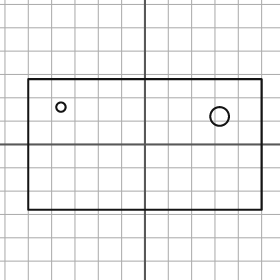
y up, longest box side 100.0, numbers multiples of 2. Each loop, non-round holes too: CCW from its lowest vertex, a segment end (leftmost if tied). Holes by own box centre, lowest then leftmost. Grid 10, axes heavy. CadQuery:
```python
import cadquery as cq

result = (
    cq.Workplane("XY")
    .moveTo(-50.0, -28.0)
    .lineTo(50.0, -28.0)
    .lineTo(50.0, 28.0)
    .lineTo(-50.0, 28.0)
    .close()
    .moveTo(32.0, 12.0)
    .circle(4.0)
    .moveTo(-36.0, 16.0)
    .circle(2.0)
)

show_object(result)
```